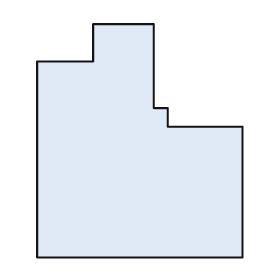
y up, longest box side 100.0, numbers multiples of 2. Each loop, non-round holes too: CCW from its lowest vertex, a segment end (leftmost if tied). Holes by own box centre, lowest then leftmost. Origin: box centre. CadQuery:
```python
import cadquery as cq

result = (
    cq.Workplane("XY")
    .moveTo(-44.0, -50.0)
    .lineTo(44.0, -50.0)
    .lineTo(44.0, 6.0)
    .lineTo(12.0, 6.0)
    .lineTo(12.0, 14.0)
    .lineTo(6.0, 14.0)
    .lineTo(6.0, 50.0)
    .lineTo(-20.0, 50.0)
    .lineTo(-20.0, 34.0)
    .lineTo(-44.0, 34.0)
    .close()
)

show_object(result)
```